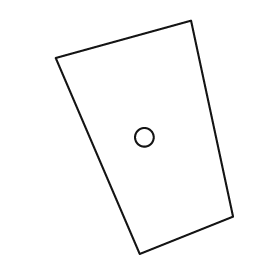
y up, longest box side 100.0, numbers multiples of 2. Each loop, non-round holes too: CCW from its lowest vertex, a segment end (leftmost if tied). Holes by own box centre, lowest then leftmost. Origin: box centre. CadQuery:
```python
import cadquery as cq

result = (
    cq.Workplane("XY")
    .moveTo(-2.0, -50.0)
    .lineTo(38.0, -34.0)
    .lineTo(20.0, 50.0)
    .lineTo(-38.0, 34.0)
    .close()
    .moveTo(0.0, 0.0)
    .circle(4.0)
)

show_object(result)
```